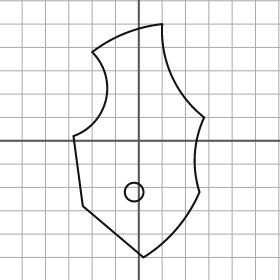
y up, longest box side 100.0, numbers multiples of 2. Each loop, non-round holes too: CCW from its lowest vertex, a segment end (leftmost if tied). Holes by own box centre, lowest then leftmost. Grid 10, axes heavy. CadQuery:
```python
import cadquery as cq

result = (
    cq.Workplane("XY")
    .moveTo(2.0, -50.0)
    .threePointArc((16.0, -38.0), (26.0, -22.0))
    .threePointArc((24.0, -6.0), (28.0, 10.0))
    .threePointArc((14.0, 28.0), (10.0, 50.0))
    .threePointArc((-6.0, 46.0), (-20.0, 38.0))
    .threePointArc((-14.0, 18.0), (-28.0, 2.0))
    .lineTo(-24.0, -28.0)
    .close()
    .moveTo(-2.0, -22.0)
    .circle(4.0)
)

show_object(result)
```